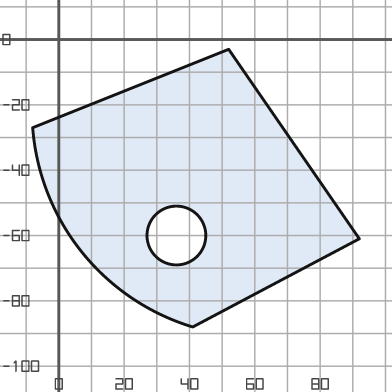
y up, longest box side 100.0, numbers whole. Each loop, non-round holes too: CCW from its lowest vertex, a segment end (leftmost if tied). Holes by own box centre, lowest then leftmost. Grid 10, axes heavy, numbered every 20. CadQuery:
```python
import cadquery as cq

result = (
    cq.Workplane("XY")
    .moveTo(41.0, -88.0)
    .lineTo(92.0, -61.0)
    .lineTo(52.0, -3.0)
    .lineTo(-8.0, -27.0)
    .threePointArc((7.0, -65.0), (41.0, -88.0))
    .close()
    .moveTo(36.0, -60.0)
    .circle(9.0)
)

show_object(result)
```